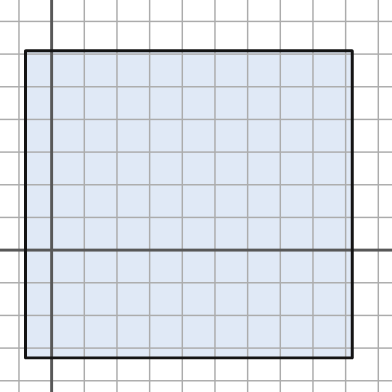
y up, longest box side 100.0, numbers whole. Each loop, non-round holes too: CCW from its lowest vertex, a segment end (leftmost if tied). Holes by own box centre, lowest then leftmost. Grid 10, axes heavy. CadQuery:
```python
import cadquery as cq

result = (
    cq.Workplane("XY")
    .moveTo(-8.0, -33.0)
    .lineTo(92.0, -33.0)
    .lineTo(92.0, 61.0)
    .lineTo(-8.0, 61.0)
    .close()
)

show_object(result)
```